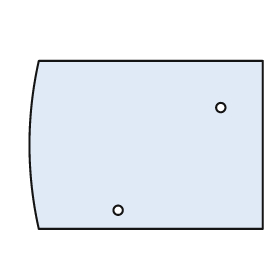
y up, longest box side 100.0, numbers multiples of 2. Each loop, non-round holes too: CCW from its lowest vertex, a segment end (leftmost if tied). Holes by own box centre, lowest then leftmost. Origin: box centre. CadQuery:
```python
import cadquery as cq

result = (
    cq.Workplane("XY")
    .moveTo(-46.0, -36.0)
    .lineTo(50.0, -36.0)
    .lineTo(50.0, 36.0)
    .lineTo(-46.0, 36.0)
    .threePointArc((-50.0, 0.0), (-46.0, -36.0))
    .close()
    .moveTo(-12.0, -28.0)
    .circle(2.0)
    .moveTo(32.0, 16.0)
    .circle(2.0)
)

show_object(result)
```